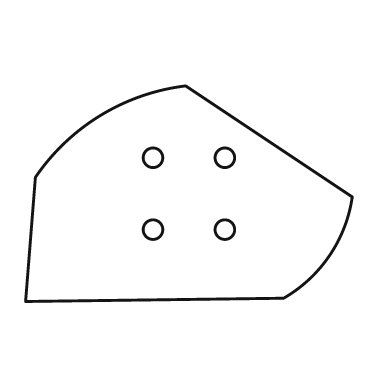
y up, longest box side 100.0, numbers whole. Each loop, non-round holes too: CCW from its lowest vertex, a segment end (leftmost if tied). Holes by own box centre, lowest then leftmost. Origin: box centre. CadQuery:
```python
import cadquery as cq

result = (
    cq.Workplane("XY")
    .moveTo(-50.0, -33.0)
    .lineTo(29.0, -32.0)
    .threePointArc((43.0, -19.0), (50.0, -1.0))
    .lineTo(-1.0, 33.0)
    .threePointArc((-27.0, 24.0), (-47.0, 5.0))
    .close()
    .moveTo(-11.0, -11.0)
    .circle(3.0)
    .moveTo(11.0, -11.0)
    .circle(3.0)
    .moveTo(-11.0, 11.0)
    .circle(3.0)
    .moveTo(11.0, 11.0)
    .circle(3.0)
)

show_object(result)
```